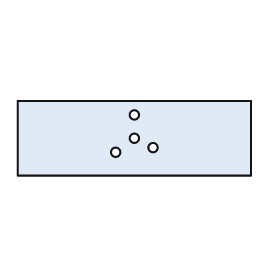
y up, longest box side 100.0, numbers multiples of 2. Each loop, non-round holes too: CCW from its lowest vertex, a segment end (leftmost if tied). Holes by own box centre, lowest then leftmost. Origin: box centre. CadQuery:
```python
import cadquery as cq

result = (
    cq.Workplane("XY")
    .moveTo(-50.0, -16.0)
    .lineTo(50.0, -16.0)
    .lineTo(50.0, 16.0)
    .lineTo(-50.0, 16.0)
    .close()
    .moveTo(-8.0, -6.0)
    .circle(2.0)
    .moveTo(8.0, -4.0)
    .circle(2.0)
    .moveTo(0.0, 0.0)
    .circle(2.0)
    .moveTo(0.0, 10.0)
    .circle(2.0)
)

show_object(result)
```